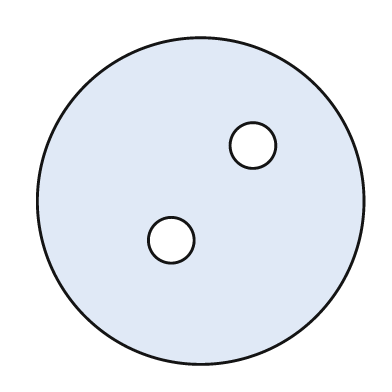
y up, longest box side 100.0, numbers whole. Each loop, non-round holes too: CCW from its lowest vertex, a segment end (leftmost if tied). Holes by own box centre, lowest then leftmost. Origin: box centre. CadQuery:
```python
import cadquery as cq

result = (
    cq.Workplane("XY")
    .moveTo(0.0, 0.0)
    .circle(50.0)
    .moveTo(-9.0, -12.0)
    .circle(7.0)
    .moveTo(16.0, 17.0)
    .circle(7.0)
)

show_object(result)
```